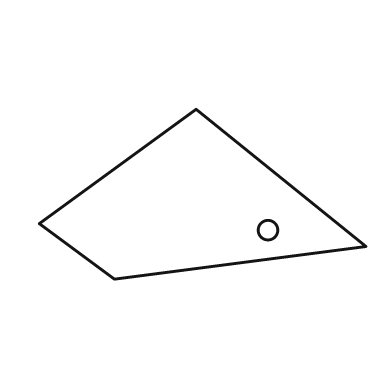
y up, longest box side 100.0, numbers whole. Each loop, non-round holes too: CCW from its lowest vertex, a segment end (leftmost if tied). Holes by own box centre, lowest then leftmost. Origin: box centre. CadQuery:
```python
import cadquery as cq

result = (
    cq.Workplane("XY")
    .moveTo(-27.0, -26.0)
    .lineTo(50.0, -16.0)
    .lineTo(-2.0, 26.0)
    .lineTo(-50.0, -9.0)
    .close()
    .moveTo(20.0, -11.0)
    .circle(3.0)
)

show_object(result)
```